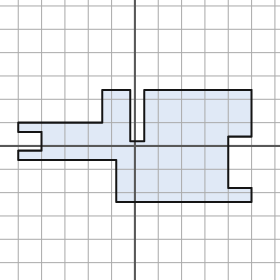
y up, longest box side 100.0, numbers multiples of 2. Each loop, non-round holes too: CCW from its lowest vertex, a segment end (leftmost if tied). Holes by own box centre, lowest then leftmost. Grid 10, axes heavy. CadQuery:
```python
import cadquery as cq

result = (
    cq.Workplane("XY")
    .moveTo(-8.0, -24.0)
    .lineTo(50.0, -24.0)
    .lineTo(50.0, -18.0)
    .lineTo(40.0, -18.0)
    .lineTo(40.0, 4.0)
    .lineTo(50.0, 4.0)
    .lineTo(50.0, 24.0)
    .lineTo(4.0, 24.0)
    .lineTo(4.0, 2.0)
    .lineTo(-2.0, 2.0)
    .lineTo(-2.0, 24.0)
    .lineTo(-14.0, 24.0)
    .lineTo(-14.0, 10.0)
    .lineTo(-50.0, 10.0)
    .lineTo(-50.0, 6.0)
    .lineTo(-40.0, 6.0)
    .lineTo(-40.0, -2.0)
    .lineTo(-50.0, -2.0)
    .lineTo(-50.0, -6.0)
    .lineTo(-8.0, -6.0)
    .close()
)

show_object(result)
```